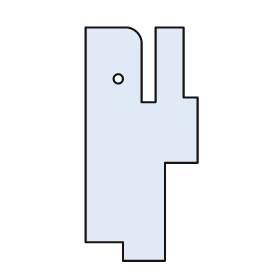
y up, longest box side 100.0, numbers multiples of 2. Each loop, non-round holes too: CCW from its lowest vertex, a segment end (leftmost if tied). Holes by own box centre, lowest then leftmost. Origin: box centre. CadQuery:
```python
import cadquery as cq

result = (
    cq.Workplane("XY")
    .moveTo(-8.0, -50.0)
    .lineTo(10.0, -50.0)
    .lineTo(10.0, -8.0)
    .lineTo(24.0, -8.0)
    .lineTo(24.0, 20.0)
    .lineTo(18.0, 20.0)
    .lineTo(18.0, 50.0)
    .lineTo(6.0, 50.0)
    .lineTo(6.0, 18.0)
    .lineTo(0.0, 18.0)
    .lineTo(0.0, 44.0)
    .threePointArc((-2.0, 48.0), (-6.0, 50.0))
    .lineTo(-24.0, 50.0)
    .lineTo(-24.0, -42.0)
    .lineTo(-8.0, -42.0)
    .close()
    .moveTo(-10.0, 28.0)
    .circle(2.0)
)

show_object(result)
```